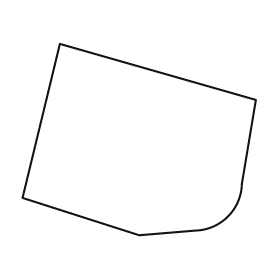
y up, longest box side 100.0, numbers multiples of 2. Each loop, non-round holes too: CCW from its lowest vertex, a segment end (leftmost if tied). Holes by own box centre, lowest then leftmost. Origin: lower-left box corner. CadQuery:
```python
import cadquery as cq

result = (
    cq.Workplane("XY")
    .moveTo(50.0, 0.0)
    .lineTo(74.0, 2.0)
    .threePointArc((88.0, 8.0), (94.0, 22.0))
    .lineTo(100.0, 58.0)
    .lineTo(16.0, 82.0)
    .lineTo(0.0, 16.0)
    .close()
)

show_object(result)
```